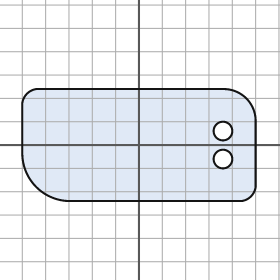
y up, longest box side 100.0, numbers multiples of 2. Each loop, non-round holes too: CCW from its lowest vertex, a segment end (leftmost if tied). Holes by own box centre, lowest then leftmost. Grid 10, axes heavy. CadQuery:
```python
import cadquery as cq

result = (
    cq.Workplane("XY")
    .moveTo(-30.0, -24.0)
    .lineTo(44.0, -24.0)
    .threePointArc((48.0, -22.0), (50.0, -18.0))
    .lineTo(50.0, 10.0)
    .threePointArc((46.0, 20.0), (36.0, 24.0))
    .lineTo(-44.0, 24.0)
    .threePointArc((-48.0, 22.0), (-50.0, 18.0))
    .lineTo(-50.0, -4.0)
    .threePointArc((-44.0, -18.0), (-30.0, -24.0))
    .close()
    .moveTo(36.0, -6.0)
    .circle(4.0)
    .moveTo(36.0, 6.0)
    .circle(4.0)
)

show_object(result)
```